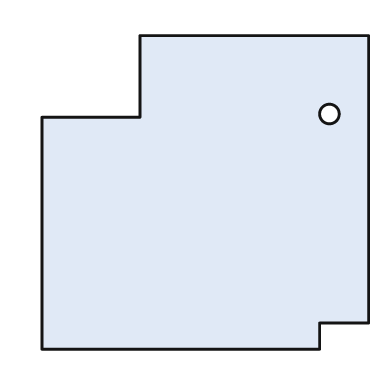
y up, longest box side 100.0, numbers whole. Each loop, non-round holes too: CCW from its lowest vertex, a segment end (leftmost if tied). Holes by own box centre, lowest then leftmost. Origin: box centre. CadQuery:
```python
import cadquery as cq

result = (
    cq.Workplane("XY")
    .moveTo(-50.0, -48.0)
    .lineTo(35.0, -48.0)
    .lineTo(35.0, -40.0)
    .lineTo(50.0, -40.0)
    .lineTo(50.0, 48.0)
    .lineTo(-20.0, 48.0)
    .lineTo(-20.0, 23.0)
    .lineTo(-50.0, 23.0)
    .close()
    .moveTo(38.0, 24.0)
    .circle(3.0)
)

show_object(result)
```